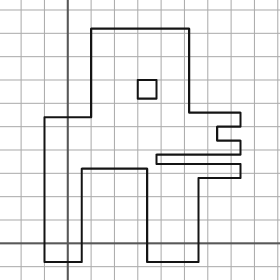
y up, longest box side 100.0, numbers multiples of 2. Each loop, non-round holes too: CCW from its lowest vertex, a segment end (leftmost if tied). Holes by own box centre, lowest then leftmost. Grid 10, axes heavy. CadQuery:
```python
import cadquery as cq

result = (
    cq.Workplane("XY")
    .moveTo(-10.0, -8.0)
    .lineTo(6.0, -8.0)
    .lineTo(6.0, 32.0)
    .lineTo(34.0, 32.0)
    .lineTo(34.0, -8.0)
    .lineTo(56.0, -8.0)
    .lineTo(56.0, 28.0)
    .lineTo(74.0, 28.0)
    .lineTo(74.0, 34.0)
    .lineTo(38.0, 34.0)
    .lineTo(38.0, 38.0)
    .lineTo(74.0, 38.0)
    .lineTo(74.0, 44.0)
    .lineTo(64.0, 44.0)
    .lineTo(64.0, 50.0)
    .lineTo(74.0, 50.0)
    .lineTo(74.0, 56.0)
    .lineTo(52.0, 56.0)
    .lineTo(52.0, 92.0)
    .lineTo(10.0, 92.0)
    .lineTo(10.0, 54.0)
    .lineTo(-10.0, 54.0)
    .close()
    .moveTo(30.0, 62.0)
    .lineTo(38.0, 62.0)
    .lineTo(38.0, 70.0)
    .lineTo(30.0, 70.0)
    .close()
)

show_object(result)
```